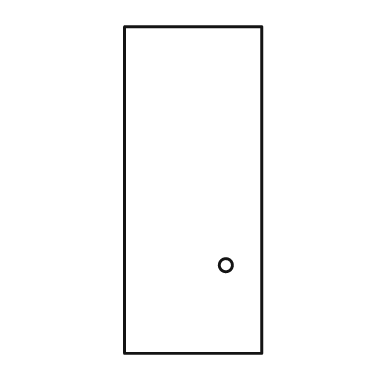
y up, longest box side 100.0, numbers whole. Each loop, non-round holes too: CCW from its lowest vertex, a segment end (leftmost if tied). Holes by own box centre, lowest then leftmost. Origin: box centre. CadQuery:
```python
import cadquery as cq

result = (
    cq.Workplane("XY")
    .moveTo(-21.0, -50.0)
    .lineTo(21.0, -50.0)
    .lineTo(21.0, 50.0)
    .lineTo(-21.0, 50.0)
    .close()
    .moveTo(10.0, -23.0)
    .circle(2.0)
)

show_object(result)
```